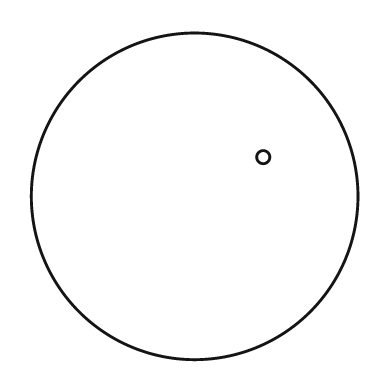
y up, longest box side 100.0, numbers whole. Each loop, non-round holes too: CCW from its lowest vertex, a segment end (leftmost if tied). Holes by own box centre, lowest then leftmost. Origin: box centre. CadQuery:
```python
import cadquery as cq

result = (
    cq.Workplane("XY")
    .moveTo(0.0, 0.0)
    .circle(50.0)
    .moveTo(21.0, 12.0)
    .circle(2.0)
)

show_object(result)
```